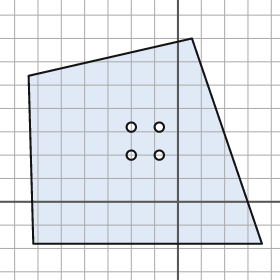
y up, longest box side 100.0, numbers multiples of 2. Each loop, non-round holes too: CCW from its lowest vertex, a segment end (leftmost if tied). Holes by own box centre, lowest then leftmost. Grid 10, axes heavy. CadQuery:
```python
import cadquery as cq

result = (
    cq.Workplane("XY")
    .moveTo(-62.0, -18.0)
    .lineTo(36.0, -18.0)
    .lineTo(6.0, 70.0)
    .lineTo(-64.0, 54.0)
    .close()
    .moveTo(-20.0, 20.0)
    .circle(2.0)
    .moveTo(-8.0, 20.0)
    .circle(2.0)
    .moveTo(-20.0, 32.0)
    .circle(2.0)
    .moveTo(-8.0, 32.0)
    .circle(2.0)
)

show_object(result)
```